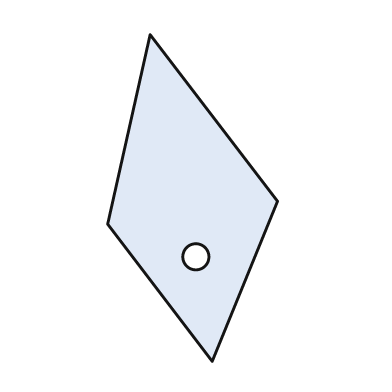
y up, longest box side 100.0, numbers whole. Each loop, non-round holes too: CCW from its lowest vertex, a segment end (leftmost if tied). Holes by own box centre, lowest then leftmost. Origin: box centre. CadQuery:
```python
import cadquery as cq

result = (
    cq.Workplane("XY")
    .moveTo(6.0, -50.0)
    .lineTo(26.0, -1.0)
    .lineTo(-13.0, 50.0)
    .lineTo(-26.0, -8.0)
    .close()
    .moveTo(1.0, -18.0)
    .circle(4.0)
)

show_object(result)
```